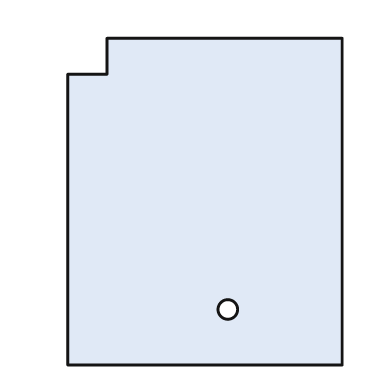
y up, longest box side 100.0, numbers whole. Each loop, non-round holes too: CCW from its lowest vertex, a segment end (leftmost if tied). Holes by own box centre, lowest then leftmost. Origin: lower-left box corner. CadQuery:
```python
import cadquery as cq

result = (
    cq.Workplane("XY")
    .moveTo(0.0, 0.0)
    .lineTo(84.0, 0.0)
    .lineTo(84.0, 100.0)
    .lineTo(12.0, 100.0)
    .lineTo(12.0, 89.0)
    .lineTo(0.0, 89.0)
    .close()
    .moveTo(49.0, 17.0)
    .circle(3.0)
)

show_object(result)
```